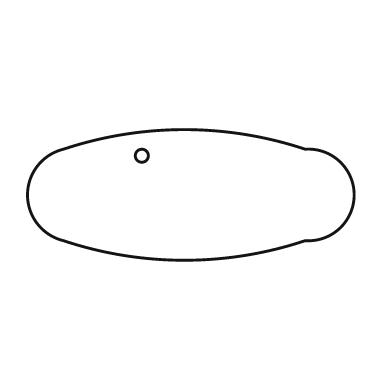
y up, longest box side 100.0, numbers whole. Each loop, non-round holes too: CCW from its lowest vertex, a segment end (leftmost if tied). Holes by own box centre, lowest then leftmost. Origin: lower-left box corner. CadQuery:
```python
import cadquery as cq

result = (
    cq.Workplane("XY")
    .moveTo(11.0, 6.0)
    .threePointArc((48.0, 0.0), (85.0, 6.0))
    .threePointArc((100.0, 20.0), (85.0, 34.0))
    .threePointArc((48.0, 40.0), (11.0, 34.0))
    .threePointArc((0.0, 20.0), (11.0, 6.0))
    .close()
    .moveTo(35.0, 32.0)
    .circle(2.0)
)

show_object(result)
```